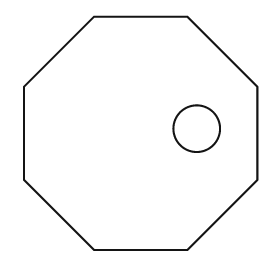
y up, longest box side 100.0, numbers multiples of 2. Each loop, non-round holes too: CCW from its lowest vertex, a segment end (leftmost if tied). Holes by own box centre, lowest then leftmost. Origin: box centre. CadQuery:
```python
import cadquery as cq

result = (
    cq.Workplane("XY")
    .moveTo(-20.0, -50.0)
    .lineTo(20.0, -50.0)
    .lineTo(50.0, -20.0)
    .lineTo(50.0, 20.0)
    .lineTo(20.0, 50.0)
    .lineTo(-20.0, 50.0)
    .lineTo(-50.0, 20.0)
    .lineTo(-50.0, -20.0)
    .close()
    .moveTo(24.0, 2.0)
    .circle(10.0)
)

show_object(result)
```